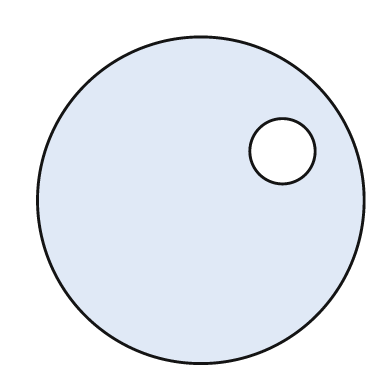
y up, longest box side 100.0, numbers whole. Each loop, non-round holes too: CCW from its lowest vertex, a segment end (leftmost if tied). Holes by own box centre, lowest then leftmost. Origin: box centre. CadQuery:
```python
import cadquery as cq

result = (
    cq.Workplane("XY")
    .moveTo(0.0, 0.0)
    .circle(50.0)
    .moveTo(25.0, 15.0)
    .circle(10.0)
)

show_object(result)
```